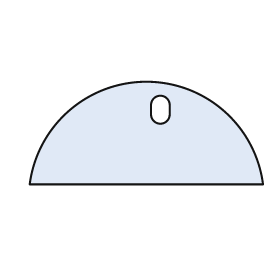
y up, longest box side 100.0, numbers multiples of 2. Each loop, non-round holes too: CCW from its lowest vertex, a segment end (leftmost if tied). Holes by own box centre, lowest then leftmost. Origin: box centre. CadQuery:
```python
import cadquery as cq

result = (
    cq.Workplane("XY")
    .moveTo(-50.0, -22.0)
    .lineTo(50.0, -22.0)
    .threePointArc((0.0, 22.0), (-50.0, -22.0))
    .close()
    .moveTo(2.0, 8.0)
    .threePointArc((6.0, 4.0), (10.0, 8.0))
    .lineTo(10.0, 12.0)
    .threePointArc((6.0, 16.0), (2.0, 12.0))
    .close()
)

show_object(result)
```